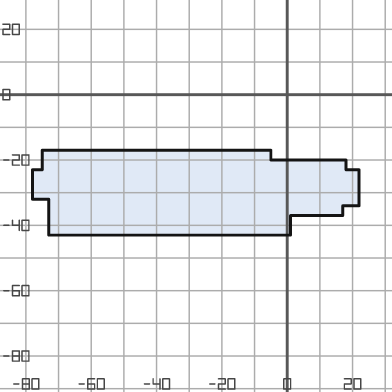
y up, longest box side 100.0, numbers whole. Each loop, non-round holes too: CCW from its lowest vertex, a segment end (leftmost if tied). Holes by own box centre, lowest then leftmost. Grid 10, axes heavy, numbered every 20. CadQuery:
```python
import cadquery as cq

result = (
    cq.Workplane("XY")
    .moveTo(-73.0, -43.0)
    .lineTo(1.0, -43.0)
    .lineTo(1.0, -37.0)
    .lineTo(17.0, -37.0)
    .lineTo(17.0, -34.0)
    .lineTo(22.0, -34.0)
    .lineTo(22.0, -23.0)
    .lineTo(18.0, -23.0)
    .lineTo(18.0, -20.0)
    .lineTo(-5.0, -20.0)
    .lineTo(-5.0, -17.0)
    .lineTo(-75.0, -17.0)
    .lineTo(-75.0, -23.0)
    .lineTo(-78.0, -23.0)
    .lineTo(-78.0, -32.0)
    .lineTo(-73.0, -32.0)
    .close()
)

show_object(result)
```